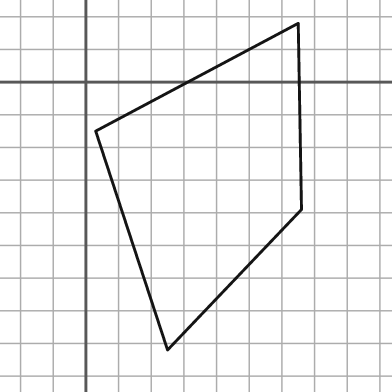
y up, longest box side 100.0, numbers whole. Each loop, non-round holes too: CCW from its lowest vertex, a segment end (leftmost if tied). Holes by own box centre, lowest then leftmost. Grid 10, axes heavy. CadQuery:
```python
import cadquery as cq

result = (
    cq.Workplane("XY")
    .moveTo(25.0, -82.0)
    .lineTo(66.0, -39.0)
    .lineTo(65.0, 18.0)
    .lineTo(3.0, -15.0)
    .close()
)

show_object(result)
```